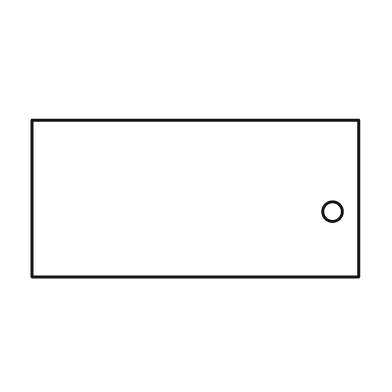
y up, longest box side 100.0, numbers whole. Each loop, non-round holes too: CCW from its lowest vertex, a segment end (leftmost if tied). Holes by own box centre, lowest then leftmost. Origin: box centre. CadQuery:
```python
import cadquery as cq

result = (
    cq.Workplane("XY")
    .moveTo(-50.0, -24.0)
    .lineTo(50.0, -24.0)
    .lineTo(50.0, 24.0)
    .lineTo(-50.0, 24.0)
    .close()
    .moveTo(42.0, -4.0)
    .circle(3.0)
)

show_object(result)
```